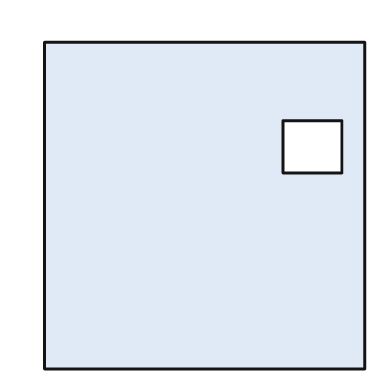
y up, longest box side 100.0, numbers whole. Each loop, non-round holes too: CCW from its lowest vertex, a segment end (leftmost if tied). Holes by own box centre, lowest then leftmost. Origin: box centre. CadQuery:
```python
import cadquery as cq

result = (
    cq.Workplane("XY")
    .moveTo(-49.0, -50.0)
    .lineTo(49.0, -50.0)
    .lineTo(49.0, 50.0)
    .lineTo(-49.0, 50.0)
    .close()
    .moveTo(24.0, 10.0)
    .lineTo(42.0, 10.0)
    .lineTo(42.0, 26.0)
    .lineTo(24.0, 26.0)
    .close()
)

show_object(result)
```